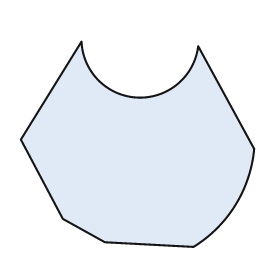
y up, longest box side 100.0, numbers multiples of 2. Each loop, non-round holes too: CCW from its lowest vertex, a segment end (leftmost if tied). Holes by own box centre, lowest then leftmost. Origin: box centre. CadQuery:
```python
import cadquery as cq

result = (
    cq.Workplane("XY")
    .moveTo(24.0, -44.0)
    .threePointArc((42.0, -26.0), (50.0, -2.0))
    .lineTo(26.0, 42.0)
    .threePointArc((0.0, 20.0), (-24.0, 44.0))
    .lineTo(-50.0, 2.0)
    .lineTo(-32.0, -32.0)
    .lineTo(-14.0, -42.0)
    .close()
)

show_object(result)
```